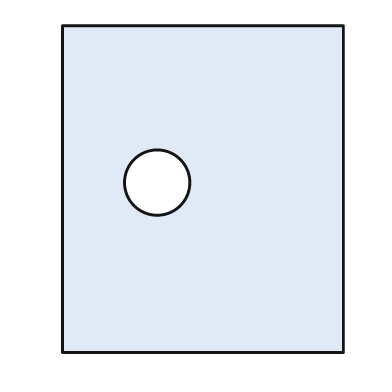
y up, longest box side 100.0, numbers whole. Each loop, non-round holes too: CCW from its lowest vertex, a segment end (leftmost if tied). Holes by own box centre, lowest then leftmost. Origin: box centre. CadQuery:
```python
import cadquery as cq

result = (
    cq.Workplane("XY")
    .moveTo(-43.0, -50.0)
    .lineTo(43.0, -50.0)
    .lineTo(43.0, 50.0)
    .lineTo(-43.0, 50.0)
    .close()
    .moveTo(-14.0, 2.0)
    .circle(10.0)
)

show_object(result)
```